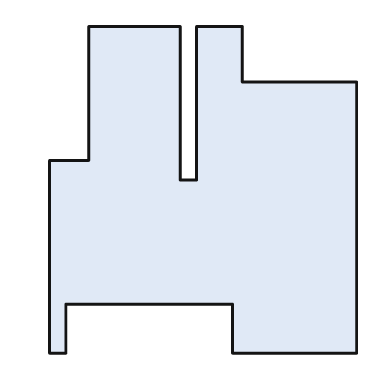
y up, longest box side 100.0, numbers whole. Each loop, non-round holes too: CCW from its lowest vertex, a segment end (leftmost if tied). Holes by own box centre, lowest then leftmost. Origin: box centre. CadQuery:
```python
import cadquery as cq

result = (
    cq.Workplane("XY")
    .moveTo(-47.0, -50.0)
    .lineTo(-42.0, -50.0)
    .lineTo(-42.0, -35.0)
    .lineTo(9.0, -35.0)
    .lineTo(9.0, -50.0)
    .lineTo(47.0, -50.0)
    .lineTo(47.0, 33.0)
    .lineTo(12.0, 33.0)
    .lineTo(12.0, 50.0)
    .lineTo(-2.0, 50.0)
    .lineTo(-2.0, 3.0)
    .lineTo(-7.0, 3.0)
    .lineTo(-7.0, 50.0)
    .lineTo(-35.0, 50.0)
    .lineTo(-35.0, 9.0)
    .lineTo(-47.0, 9.0)
    .close()
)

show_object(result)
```